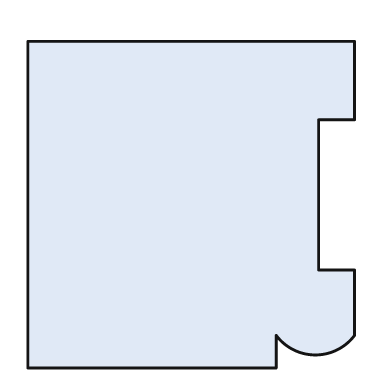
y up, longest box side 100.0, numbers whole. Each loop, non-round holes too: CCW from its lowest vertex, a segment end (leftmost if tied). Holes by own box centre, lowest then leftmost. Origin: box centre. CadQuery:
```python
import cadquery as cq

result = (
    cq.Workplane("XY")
    .moveTo(-50.0, -50.0)
    .lineTo(26.0, -50.0)
    .lineTo(26.0, -40.0)
    .threePointArc((38.0, -46.0), (50.0, -40.0))
    .lineTo(50.0, -20.0)
    .lineTo(39.0, -20.0)
    .lineTo(39.0, 26.0)
    .lineTo(50.0, 26.0)
    .lineTo(50.0, 50.0)
    .lineTo(-50.0, 50.0)
    .close()
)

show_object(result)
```